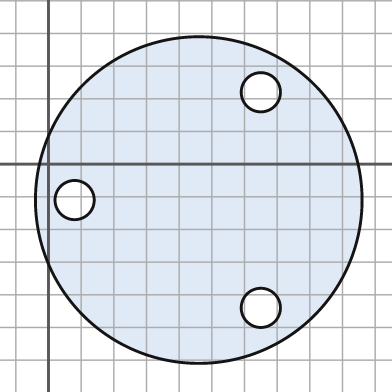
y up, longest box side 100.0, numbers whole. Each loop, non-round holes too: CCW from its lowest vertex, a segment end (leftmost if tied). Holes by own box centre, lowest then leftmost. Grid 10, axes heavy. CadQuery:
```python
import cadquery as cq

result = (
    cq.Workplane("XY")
    .moveTo(46.0, -11.0)
    .circle(50.0)
    .moveTo(65.0, -44.0)
    .circle(6.0)
    .moveTo(8.0, -11.0)
    .circle(6.0)
    .moveTo(65.0, 22.0)
    .circle(6.0)
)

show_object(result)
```